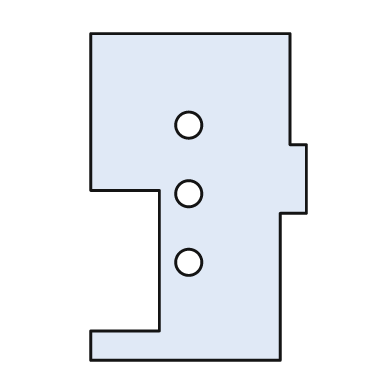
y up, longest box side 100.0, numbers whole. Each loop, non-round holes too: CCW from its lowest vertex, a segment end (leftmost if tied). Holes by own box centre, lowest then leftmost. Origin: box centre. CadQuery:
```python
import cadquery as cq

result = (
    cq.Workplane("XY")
    .moveTo(-33.0, -50.0)
    .lineTo(25.0, -50.0)
    .lineTo(25.0, -5.0)
    .lineTo(33.0, -5.0)
    .lineTo(33.0, 16.0)
    .lineTo(28.0, 16.0)
    .lineTo(28.0, 50.0)
    .lineTo(-33.0, 50.0)
    .lineTo(-33.0, 2.0)
    .lineTo(-12.0, 2.0)
    .lineTo(-12.0, -41.0)
    .lineTo(-33.0, -41.0)
    .close()
    .moveTo(-3.0, -20.0)
    .circle(4.0)
    .moveTo(-3.0, 1.0)
    .circle(4.0)
    .moveTo(-3.0, 22.0)
    .circle(4.0)
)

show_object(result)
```